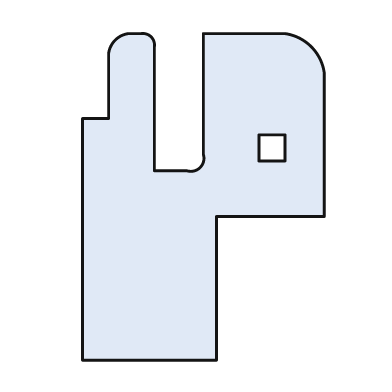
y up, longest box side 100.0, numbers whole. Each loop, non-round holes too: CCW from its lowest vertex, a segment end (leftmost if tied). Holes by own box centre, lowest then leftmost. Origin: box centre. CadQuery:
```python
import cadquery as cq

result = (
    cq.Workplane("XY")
    .moveTo(-37.0, -50.0)
    .lineTo(4.0, -50.0)
    .lineTo(4.0, -6.0)
    .lineTo(37.0, -6.0)
    .lineTo(37.0, 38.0)
    .threePointArc((33.0, 46.0), (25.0, 50.0))
    .lineTo(0.0, 50.0)
    .lineTo(0.0, 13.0)
    .threePointArc((-1.0, 9.0), (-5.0, 8.0))
    .lineTo(-15.0, 8.0)
    .lineTo(-15.0, 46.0)
    .threePointArc((-16.0, 49.0), (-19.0, 50.0))
    .lineTo(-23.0, 50.0)
    .threePointArc((-27.0, 48.0), (-29.0, 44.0))
    .lineTo(-29.0, 24.0)
    .lineTo(-37.0, 24.0)
    .close()
    .moveTo(17.0, 11.0)
    .lineTo(25.0, 11.0)
    .lineTo(25.0, 19.0)
    .lineTo(17.0, 19.0)
    .close()
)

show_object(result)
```